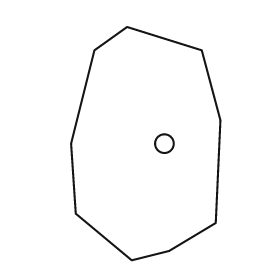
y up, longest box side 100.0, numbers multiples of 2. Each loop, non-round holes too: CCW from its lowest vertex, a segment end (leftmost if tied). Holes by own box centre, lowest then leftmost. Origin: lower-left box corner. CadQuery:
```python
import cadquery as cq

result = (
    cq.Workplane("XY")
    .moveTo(26.0, 0.0)
    .lineTo(42.0, 4.0)
    .lineTo(62.0, 16.0)
    .lineTo(64.0, 60.0)
    .lineTo(56.0, 90.0)
    .lineTo(24.0, 100.0)
    .lineTo(10.0, 90.0)
    .lineTo(0.0, 50.0)
    .lineTo(2.0, 20.0)
    .close()
    .moveTo(40.0, 50.0)
    .circle(4.0)
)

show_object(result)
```